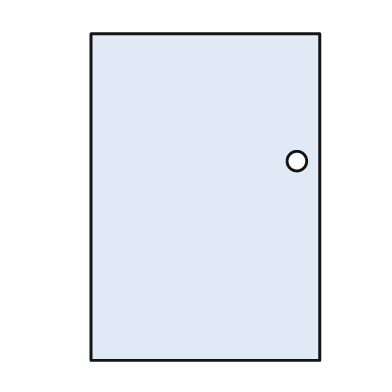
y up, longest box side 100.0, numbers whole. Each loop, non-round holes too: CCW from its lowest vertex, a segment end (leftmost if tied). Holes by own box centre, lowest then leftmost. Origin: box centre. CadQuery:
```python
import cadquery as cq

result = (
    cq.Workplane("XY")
    .moveTo(-35.0, -50.0)
    .lineTo(35.0, -50.0)
    .lineTo(35.0, 50.0)
    .lineTo(-35.0, 50.0)
    .close()
    .moveTo(28.0, 11.0)
    .circle(3.0)
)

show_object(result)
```